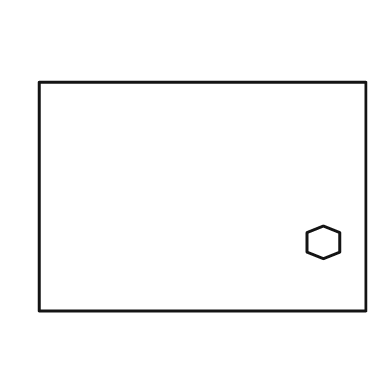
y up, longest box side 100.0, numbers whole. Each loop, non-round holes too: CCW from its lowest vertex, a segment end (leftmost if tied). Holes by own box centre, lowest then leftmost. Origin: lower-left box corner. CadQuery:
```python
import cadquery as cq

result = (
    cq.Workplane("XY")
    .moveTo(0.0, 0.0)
    .lineTo(100.0, 0.0)
    .lineTo(100.0, 70.0)
    .lineTo(0.0, 70.0)
    .close()
    .moveTo(87.0, 16.0)
    .lineTo(92.0, 18.0)
    .lineTo(92.0, 24.0)
    .lineTo(87.0, 26.0)
    .lineTo(82.0, 24.0)
    .lineTo(82.0, 18.0)
    .close()
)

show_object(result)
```